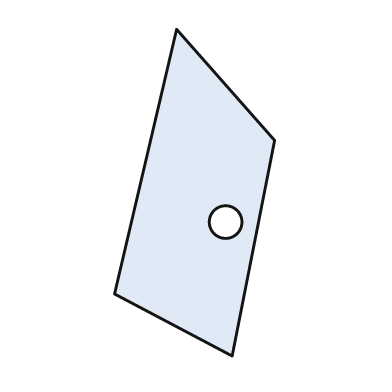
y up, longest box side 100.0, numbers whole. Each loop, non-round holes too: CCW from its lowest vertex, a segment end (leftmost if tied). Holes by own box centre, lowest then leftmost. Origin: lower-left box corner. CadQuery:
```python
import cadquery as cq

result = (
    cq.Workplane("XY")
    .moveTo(36.0, 0.0)
    .lineTo(49.0, 66.0)
    .lineTo(19.0, 100.0)
    .lineTo(0.0, 19.0)
    .close()
    .moveTo(34.0, 41.0)
    .circle(5.0)
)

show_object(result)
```